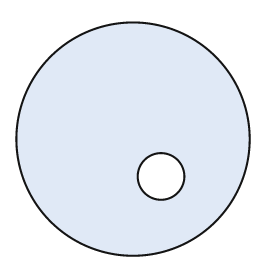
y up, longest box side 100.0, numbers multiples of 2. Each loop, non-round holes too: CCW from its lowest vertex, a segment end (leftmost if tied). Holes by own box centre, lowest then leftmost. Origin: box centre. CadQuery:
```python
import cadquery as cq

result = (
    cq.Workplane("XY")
    .moveTo(0.0, 0.0)
    .circle(50.0)
    .moveTo(12.0, -16.0)
    .circle(10.0)
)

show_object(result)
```